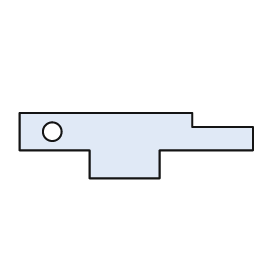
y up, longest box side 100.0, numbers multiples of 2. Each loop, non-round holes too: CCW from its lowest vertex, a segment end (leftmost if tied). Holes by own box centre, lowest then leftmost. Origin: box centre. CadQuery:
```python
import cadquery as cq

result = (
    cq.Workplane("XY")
    .moveTo(-20.0, -14.0)
    .lineTo(10.0, -14.0)
    .lineTo(10.0, -2.0)
    .lineTo(50.0, -2.0)
    .lineTo(50.0, 8.0)
    .lineTo(24.0, 8.0)
    .lineTo(24.0, 14.0)
    .lineTo(-50.0, 14.0)
    .lineTo(-50.0, -2.0)
    .lineTo(-20.0, -2.0)
    .close()
    .moveTo(-36.0, 6.0)
    .circle(4.0)
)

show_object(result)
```